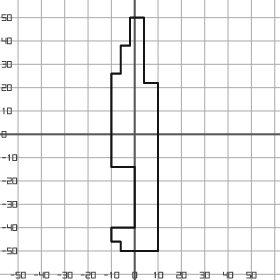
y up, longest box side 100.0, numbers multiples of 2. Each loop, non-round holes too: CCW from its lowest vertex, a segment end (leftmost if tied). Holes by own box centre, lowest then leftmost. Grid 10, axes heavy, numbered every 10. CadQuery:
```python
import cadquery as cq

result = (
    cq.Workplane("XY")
    .moveTo(-6.0, -50.0)
    .lineTo(10.0, -50.0)
    .lineTo(10.0, 22.0)
    .lineTo(4.0, 22.0)
    .lineTo(4.0, 50.0)
    .lineTo(-2.0, 50.0)
    .lineTo(-2.0, 38.0)
    .lineTo(-6.0, 38.0)
    .lineTo(-6.0, 26.0)
    .lineTo(-10.0, 26.0)
    .lineTo(-10.0, -14.0)
    .lineTo(0.0, -14.0)
    .lineTo(0.0, -40.0)
    .lineTo(-10.0, -40.0)
    .lineTo(-10.0, -46.0)
    .lineTo(-6.0, -46.0)
    .close()
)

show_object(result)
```